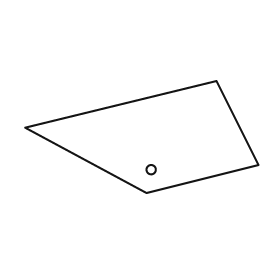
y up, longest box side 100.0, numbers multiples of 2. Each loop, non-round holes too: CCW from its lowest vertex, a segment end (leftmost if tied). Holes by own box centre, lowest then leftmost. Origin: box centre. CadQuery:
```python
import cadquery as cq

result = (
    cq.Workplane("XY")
    .moveTo(2.0, -24.0)
    .lineTo(50.0, -12.0)
    .lineTo(32.0, 24.0)
    .lineTo(-50.0, 4.0)
    .close()
    .moveTo(4.0, -14.0)
    .circle(2.0)
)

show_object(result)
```